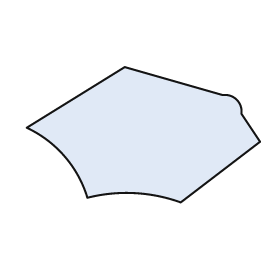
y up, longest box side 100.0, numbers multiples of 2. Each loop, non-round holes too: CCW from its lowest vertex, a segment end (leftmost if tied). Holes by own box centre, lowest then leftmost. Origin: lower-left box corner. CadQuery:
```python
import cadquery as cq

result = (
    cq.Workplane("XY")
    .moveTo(66.0, 0.0)
    .lineTo(100.0, 26.0)
    .lineTo(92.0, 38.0)
    .threePointArc((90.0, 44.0), (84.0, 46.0))
    .lineTo(42.0, 58.0)
    .lineTo(0.0, 32.0)
    .threePointArc((16.0, 20.0), (26.0, 2.0))
    .threePointArc((46.0, 4.0), (66.0, 0.0))
    .close()
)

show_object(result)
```